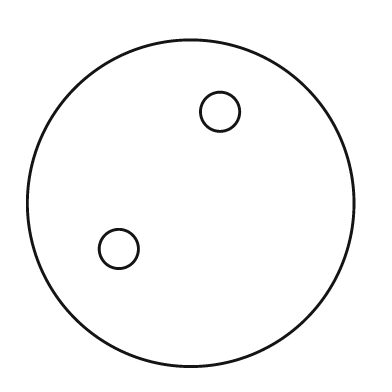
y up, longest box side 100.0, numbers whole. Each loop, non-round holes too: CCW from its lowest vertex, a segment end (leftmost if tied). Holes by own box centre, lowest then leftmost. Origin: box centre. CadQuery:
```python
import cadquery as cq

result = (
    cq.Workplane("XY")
    .moveTo(0.0, 0.0)
    .circle(50.0)
    .moveTo(-22.0, -14.0)
    .circle(6.0)
    .moveTo(9.0, 28.0)
    .circle(6.0)
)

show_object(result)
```